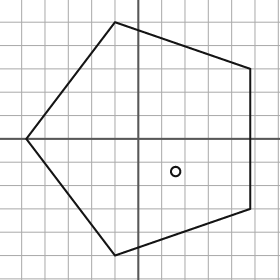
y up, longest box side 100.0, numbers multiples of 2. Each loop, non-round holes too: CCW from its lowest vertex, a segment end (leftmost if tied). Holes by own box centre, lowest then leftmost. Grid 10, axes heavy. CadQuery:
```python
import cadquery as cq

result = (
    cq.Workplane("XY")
    .moveTo(-10.0, -50.0)
    .lineTo(48.0, -30.0)
    .lineTo(48.0, 30.0)
    .lineTo(-10.0, 50.0)
    .lineTo(-48.0, 0.0)
    .close()
    .moveTo(16.0, -14.0)
    .circle(2.0)
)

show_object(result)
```